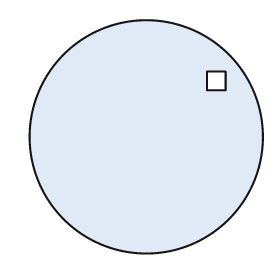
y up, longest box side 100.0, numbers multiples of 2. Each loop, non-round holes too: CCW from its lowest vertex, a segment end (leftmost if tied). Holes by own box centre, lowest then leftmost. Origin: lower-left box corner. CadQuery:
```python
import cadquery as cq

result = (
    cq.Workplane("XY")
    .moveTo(50.0, 50.0)
    .circle(50.0)
    .moveTo(76.0, 70.0)
    .lineTo(84.0, 70.0)
    .lineTo(84.0, 78.0)
    .lineTo(76.0, 78.0)
    .close()
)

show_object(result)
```